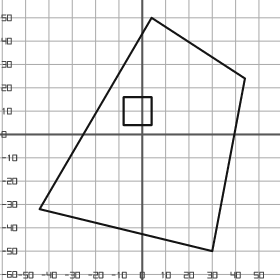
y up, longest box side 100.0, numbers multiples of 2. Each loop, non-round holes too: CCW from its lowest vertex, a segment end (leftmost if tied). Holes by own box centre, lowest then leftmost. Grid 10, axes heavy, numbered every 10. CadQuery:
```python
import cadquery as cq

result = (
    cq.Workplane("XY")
    .moveTo(30.0, -50.0)
    .lineTo(44.0, 24.0)
    .lineTo(4.0, 50.0)
    .lineTo(-44.0, -32.0)
    .close()
    .moveTo(-8.0, 4.0)
    .lineTo(4.0, 4.0)
    .lineTo(4.0, 16.0)
    .lineTo(-8.0, 16.0)
    .close()
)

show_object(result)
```